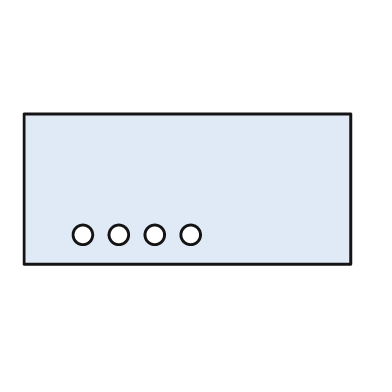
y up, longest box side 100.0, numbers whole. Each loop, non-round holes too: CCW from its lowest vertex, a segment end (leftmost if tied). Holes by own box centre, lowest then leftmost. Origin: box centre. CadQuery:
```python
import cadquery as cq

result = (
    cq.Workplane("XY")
    .moveTo(-50.0, -23.0)
    .lineTo(50.0, -23.0)
    .lineTo(50.0, 23.0)
    .lineTo(-50.0, 23.0)
    .close()
    .moveTo(-32.0, -14.0)
    .circle(3.0)
    .moveTo(-21.0, -14.0)
    .circle(3.0)
    .moveTo(-10.0, -14.0)
    .circle(3.0)
    .moveTo(1.0, -14.0)
    .circle(3.0)
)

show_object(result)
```